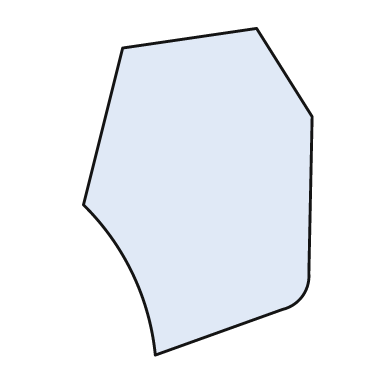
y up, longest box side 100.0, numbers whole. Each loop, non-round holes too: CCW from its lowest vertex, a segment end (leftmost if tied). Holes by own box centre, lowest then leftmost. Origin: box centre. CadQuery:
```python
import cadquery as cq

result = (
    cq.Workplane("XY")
    .moveTo(-13.0, -50.0)
    .lineTo(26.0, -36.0)
    .threePointArc((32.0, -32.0), (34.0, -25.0))
    .lineTo(35.0, 23.0)
    .lineTo(18.0, 50.0)
    .lineTo(-23.0, 44.0)
    .lineTo(-35.0, -4.0)
    .threePointArc((-20.0, -25.0), (-13.0, -50.0))
    .close()
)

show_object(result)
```